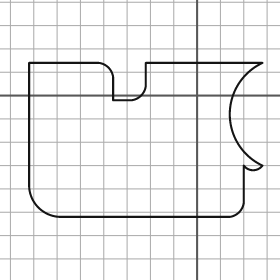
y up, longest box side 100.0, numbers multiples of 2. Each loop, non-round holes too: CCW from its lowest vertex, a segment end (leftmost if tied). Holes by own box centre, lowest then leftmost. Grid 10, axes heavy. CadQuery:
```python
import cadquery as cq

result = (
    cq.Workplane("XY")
    .moveTo(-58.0, -52.0)
    .lineTo(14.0, -52.0)
    .threePointArc((18.0, -50.0), (20.0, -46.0))
    .lineTo(20.0, -30.0)
    .threePointArc((24.0, -32.0), (28.0, -30.0))
    .threePointArc((14.0, -8.0), (28.0, 14.0))
    .lineTo(-22.0, 14.0)
    .lineTo(-22.0, 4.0)
    .threePointArc((-24.0, 0.0), (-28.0, -2.0))
    .lineTo(-36.0, -2.0)
    .lineTo(-36.0, 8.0)
    .threePointArc((-38.0, 12.0), (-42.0, 14.0))
    .lineTo(-72.0, 14.0)
    .lineTo(-72.0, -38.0)
    .threePointArc((-68.0, -48.0), (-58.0, -52.0))
    .close()
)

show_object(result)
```